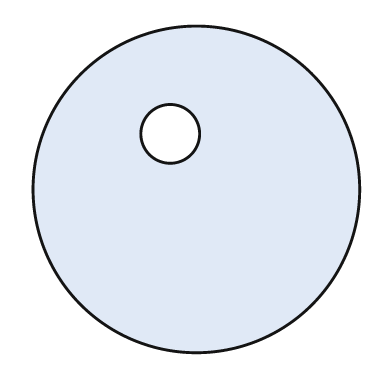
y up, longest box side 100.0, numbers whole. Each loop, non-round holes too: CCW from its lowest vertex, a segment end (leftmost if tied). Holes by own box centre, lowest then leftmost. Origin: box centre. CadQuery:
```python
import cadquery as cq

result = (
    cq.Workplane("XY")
    .moveTo(0.0, 0.0)
    .circle(50.0)
    .moveTo(-8.0, 17.0)
    .circle(9.0)
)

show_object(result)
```